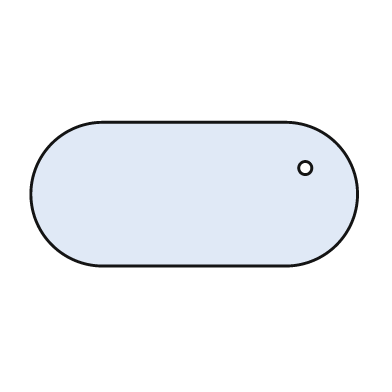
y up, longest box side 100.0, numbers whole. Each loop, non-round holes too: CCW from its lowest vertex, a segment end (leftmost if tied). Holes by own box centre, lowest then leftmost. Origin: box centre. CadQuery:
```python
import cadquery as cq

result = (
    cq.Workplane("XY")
    .moveTo(-28.0, -22.0)
    .lineTo(28.0, -22.0)
    .threePointArc((50.0, 0.0), (28.0, 22.0))
    .lineTo(-28.0, 22.0)
    .threePointArc((-50.0, 0.0), (-28.0, -22.0))
    .close()
    .moveTo(34.0, 8.0)
    .circle(2.0)
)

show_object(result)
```